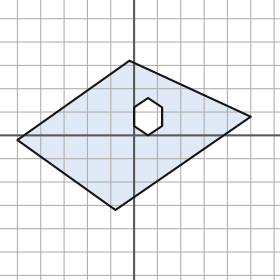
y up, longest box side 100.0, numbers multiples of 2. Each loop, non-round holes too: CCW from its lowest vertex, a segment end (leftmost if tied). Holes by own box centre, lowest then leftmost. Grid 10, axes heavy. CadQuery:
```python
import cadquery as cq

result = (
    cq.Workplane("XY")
    .moveTo(-8.0, -32.0)
    .lineTo(50.0, 8.0)
    .lineTo(-2.0, 32.0)
    .lineTo(-50.0, -2.0)
    .close()
    .moveTo(6.0, 0.0)
    .lineTo(12.0, 4.0)
    .lineTo(12.0, 12.0)
    .lineTo(6.0, 16.0)
    .lineTo(0.0, 12.0)
    .lineTo(0.0, 4.0)
    .close()
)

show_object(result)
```